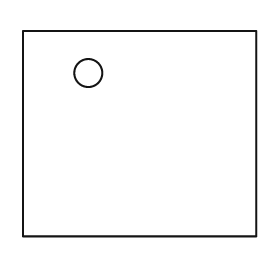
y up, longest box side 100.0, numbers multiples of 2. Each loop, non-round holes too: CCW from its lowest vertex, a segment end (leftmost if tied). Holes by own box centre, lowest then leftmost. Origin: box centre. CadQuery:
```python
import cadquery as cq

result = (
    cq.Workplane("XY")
    .moveTo(-50.0, -44.0)
    .lineTo(50.0, -44.0)
    .lineTo(50.0, 44.0)
    .lineTo(-50.0, 44.0)
    .close()
    .moveTo(-22.0, 26.0)
    .circle(6.0)
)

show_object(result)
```